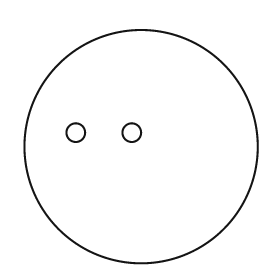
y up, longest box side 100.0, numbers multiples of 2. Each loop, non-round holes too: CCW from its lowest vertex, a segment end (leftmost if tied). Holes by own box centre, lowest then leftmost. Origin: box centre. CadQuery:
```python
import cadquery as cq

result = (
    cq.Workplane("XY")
    .moveTo(0.0, 0.0)
    .circle(50.0)
    .moveTo(-28.0, 6.0)
    .circle(4.0)
    .moveTo(-4.0, 6.0)
    .circle(4.0)
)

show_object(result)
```